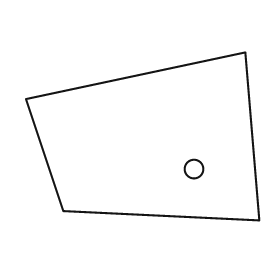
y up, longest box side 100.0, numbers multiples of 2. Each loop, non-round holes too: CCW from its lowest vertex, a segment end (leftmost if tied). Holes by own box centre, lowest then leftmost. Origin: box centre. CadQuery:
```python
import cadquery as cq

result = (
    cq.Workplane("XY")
    .moveTo(50.0, -36.0)
    .lineTo(44.0, 36.0)
    .lineTo(-50.0, 16.0)
    .lineTo(-34.0, -32.0)
    .close()
    .moveTo(22.0, -14.0)
    .circle(4.0)
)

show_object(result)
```